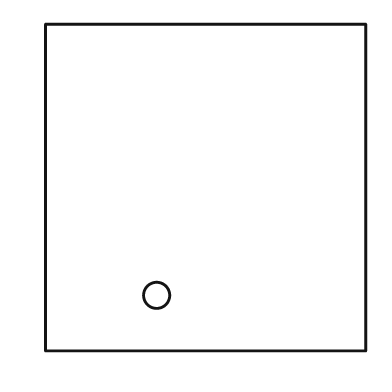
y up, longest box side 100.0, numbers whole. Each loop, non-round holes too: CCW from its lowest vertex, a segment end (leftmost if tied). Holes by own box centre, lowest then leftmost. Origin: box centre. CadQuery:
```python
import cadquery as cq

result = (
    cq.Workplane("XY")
    .moveTo(-49.0, -50.0)
    .lineTo(49.0, -50.0)
    .lineTo(49.0, 50.0)
    .lineTo(-49.0, 50.0)
    .close()
    .moveTo(-15.0, -33.0)
    .circle(4.0)
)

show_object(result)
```